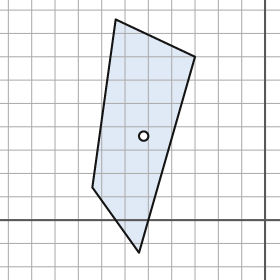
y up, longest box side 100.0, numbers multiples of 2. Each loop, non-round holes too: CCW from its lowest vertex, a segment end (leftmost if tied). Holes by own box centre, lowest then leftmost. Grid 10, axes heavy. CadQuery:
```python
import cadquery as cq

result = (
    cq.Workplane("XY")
    .moveTo(-54.0, -14.0)
    .lineTo(-30.0, 70.0)
    .lineTo(-64.0, 86.0)
    .lineTo(-74.0, 14.0)
    .close()
    .moveTo(-52.0, 36.0)
    .circle(2.0)
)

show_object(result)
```